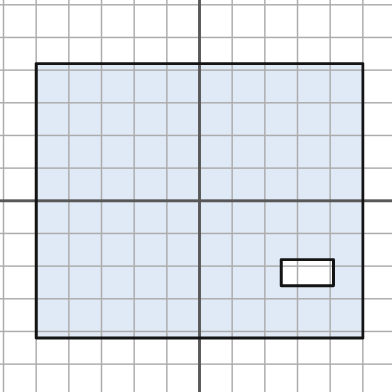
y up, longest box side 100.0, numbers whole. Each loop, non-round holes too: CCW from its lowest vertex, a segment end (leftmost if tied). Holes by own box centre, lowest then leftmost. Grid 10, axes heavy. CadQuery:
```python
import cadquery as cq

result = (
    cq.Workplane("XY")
    .moveTo(-50.0, -42.0)
    .lineTo(50.0, -42.0)
    .lineTo(50.0, 42.0)
    .lineTo(-50.0, 42.0)
    .close()
    .moveTo(25.0, -26.0)
    .lineTo(41.0, -26.0)
    .lineTo(41.0, -18.0)
    .lineTo(25.0, -18.0)
    .close()
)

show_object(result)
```